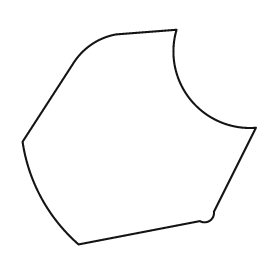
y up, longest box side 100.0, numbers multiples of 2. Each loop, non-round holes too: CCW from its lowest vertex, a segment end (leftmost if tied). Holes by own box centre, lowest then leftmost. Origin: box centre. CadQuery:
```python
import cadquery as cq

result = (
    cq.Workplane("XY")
    .moveTo(-26.0, -46.0)
    .lineTo(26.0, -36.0)
    .threePointArc((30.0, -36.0), (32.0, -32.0))
    .lineTo(50.0, 4.0)
    .threePointArc((22.0, 16.0), (16.0, 46.0))
    .lineTo(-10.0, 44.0)
    .threePointArc((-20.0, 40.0), (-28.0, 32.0))
    .lineTo(-50.0, -2.0)
    .threePointArc((-42.0, -26.0), (-26.0, -46.0))
    .close()
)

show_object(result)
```